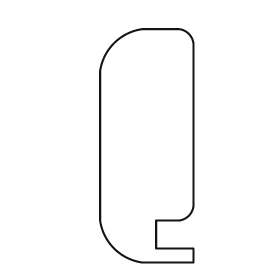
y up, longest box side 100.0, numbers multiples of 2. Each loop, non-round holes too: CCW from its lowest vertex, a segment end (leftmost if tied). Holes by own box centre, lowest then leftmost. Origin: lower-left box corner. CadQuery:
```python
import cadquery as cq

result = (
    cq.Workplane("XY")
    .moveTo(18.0, 0.0)
    .lineTo(40.0, 0.0)
    .lineTo(40.0, 6.0)
    .lineTo(24.0, 6.0)
    .lineTo(24.0, 18.0)
    .lineTo(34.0, 18.0)
    .threePointArc((38.0, 20.0), (40.0, 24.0))
    .lineTo(40.0, 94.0)
    .threePointArc((38.0, 98.0), (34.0, 100.0))
    .lineTo(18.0, 100.0)
    .threePointArc((6.0, 94.0), (0.0, 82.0))
    .lineTo(0.0, 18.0)
    .threePointArc((6.0, 6.0), (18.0, 0.0))
    .close()
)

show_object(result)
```